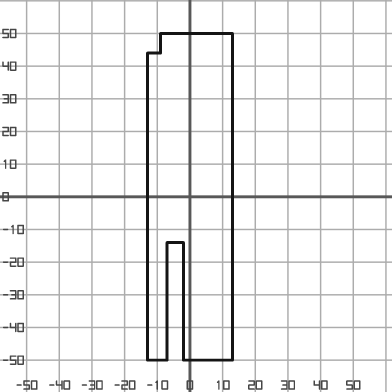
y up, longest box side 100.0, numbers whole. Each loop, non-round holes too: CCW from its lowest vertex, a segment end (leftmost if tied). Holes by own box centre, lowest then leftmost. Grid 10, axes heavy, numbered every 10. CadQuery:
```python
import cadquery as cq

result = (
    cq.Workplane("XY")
    .moveTo(-13.0, -50.0)
    .lineTo(-7.0, -50.0)
    .lineTo(-7.0, -14.0)
    .lineTo(-2.0, -14.0)
    .lineTo(-2.0, -50.0)
    .lineTo(13.0, -50.0)
    .lineTo(13.0, 50.0)
    .lineTo(-9.0, 50.0)
    .lineTo(-9.0, 44.0)
    .lineTo(-13.0, 44.0)
    .close()
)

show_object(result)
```